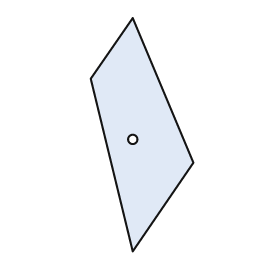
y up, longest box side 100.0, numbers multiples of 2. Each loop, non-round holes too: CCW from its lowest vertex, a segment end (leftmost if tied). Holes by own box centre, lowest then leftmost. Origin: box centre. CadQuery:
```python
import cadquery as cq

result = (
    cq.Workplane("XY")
    .moveTo(-4.0, -50.0)
    .lineTo(22.0, -12.0)
    .lineTo(-4.0, 50.0)
    .lineTo(-22.0, 24.0)
    .close()
    .moveTo(-4.0, -2.0)
    .circle(2.0)
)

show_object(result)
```